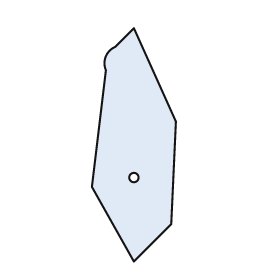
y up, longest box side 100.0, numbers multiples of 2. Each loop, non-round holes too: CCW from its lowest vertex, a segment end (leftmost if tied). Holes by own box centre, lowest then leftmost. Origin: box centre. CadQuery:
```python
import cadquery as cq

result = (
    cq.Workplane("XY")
    .moveTo(0.0, -50.0)
    .lineTo(16.0, -34.0)
    .lineTo(18.0, 10.0)
    .lineTo(0.0, 50.0)
    .lineTo(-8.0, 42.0)
    .threePointArc((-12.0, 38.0), (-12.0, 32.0))
    .lineTo(-18.0, -18.0)
    .close()
    .moveTo(0.0, -14.0)
    .circle(2.0)
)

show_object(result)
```